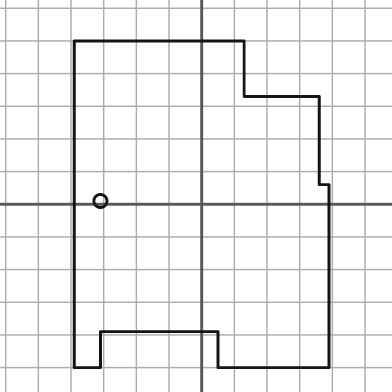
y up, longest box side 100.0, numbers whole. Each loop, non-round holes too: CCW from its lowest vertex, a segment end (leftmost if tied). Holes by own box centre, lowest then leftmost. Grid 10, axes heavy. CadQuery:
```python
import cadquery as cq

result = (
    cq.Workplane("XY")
    .moveTo(-39.0, -50.0)
    .lineTo(-31.0, -50.0)
    .lineTo(-31.0, -39.0)
    .lineTo(5.0, -39.0)
    .lineTo(5.0, -50.0)
    .lineTo(39.0, -50.0)
    .lineTo(39.0, 6.0)
    .lineTo(36.0, 6.0)
    .lineTo(36.0, 33.0)
    .lineTo(13.0, 33.0)
    .lineTo(13.0, 50.0)
    .lineTo(-39.0, 50.0)
    .close()
    .moveTo(-31.0, 1.0)
    .circle(2.0)
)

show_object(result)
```